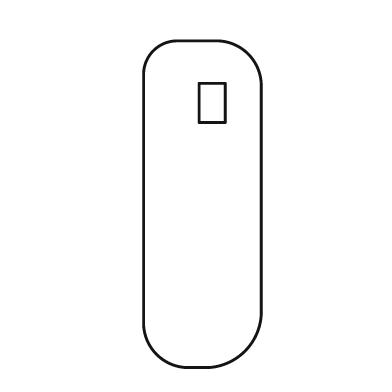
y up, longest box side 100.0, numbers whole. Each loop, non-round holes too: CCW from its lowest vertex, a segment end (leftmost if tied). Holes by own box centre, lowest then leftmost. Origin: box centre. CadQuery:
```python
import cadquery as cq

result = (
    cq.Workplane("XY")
    .moveTo(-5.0, -50.0)
    .lineTo(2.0, -50.0)
    .threePointArc((13.0, -45.0), (18.0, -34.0))
    .lineTo(18.0, 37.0)
    .threePointArc((14.0, 46.0), (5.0, 50.0))
    .lineTo(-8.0, 50.0)
    .threePointArc((-15.0, 47.0), (-18.0, 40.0))
    .lineTo(-18.0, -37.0)
    .threePointArc((-14.0, -46.0), (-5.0, -50.0))
    .close()
    .moveTo(-1.0, 25.0)
    .lineTo(7.0, 25.0)
    .lineTo(7.0, 37.0)
    .lineTo(-1.0, 37.0)
    .close()
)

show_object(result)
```